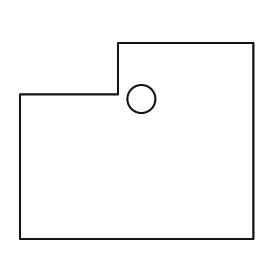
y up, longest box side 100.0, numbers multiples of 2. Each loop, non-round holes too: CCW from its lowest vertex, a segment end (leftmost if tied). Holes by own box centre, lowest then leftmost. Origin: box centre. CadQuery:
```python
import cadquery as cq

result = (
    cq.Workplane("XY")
    .moveTo(-50.0, -42.0)
    .lineTo(50.0, -42.0)
    .lineTo(50.0, 42.0)
    .lineTo(-8.0, 42.0)
    .lineTo(-8.0, 20.0)
    .lineTo(-50.0, 20.0)
    .close()
    .moveTo(2.0, 18.0)
    .circle(6.0)
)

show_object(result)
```